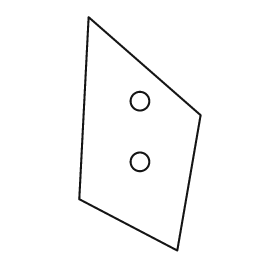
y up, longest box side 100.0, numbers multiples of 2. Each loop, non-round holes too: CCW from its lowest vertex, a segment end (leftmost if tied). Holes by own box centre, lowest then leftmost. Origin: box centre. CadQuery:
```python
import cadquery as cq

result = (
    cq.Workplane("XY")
    .moveTo(16.0, -50.0)
    .lineTo(26.0, 8.0)
    .lineTo(-22.0, 50.0)
    .lineTo(-26.0, -28.0)
    .close()
    .moveTo(0.0, -12.0)
    .circle(4.0)
    .moveTo(0.0, 14.0)
    .circle(4.0)
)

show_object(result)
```